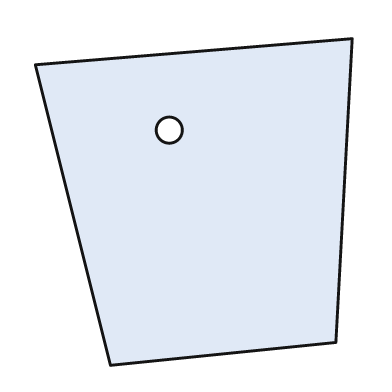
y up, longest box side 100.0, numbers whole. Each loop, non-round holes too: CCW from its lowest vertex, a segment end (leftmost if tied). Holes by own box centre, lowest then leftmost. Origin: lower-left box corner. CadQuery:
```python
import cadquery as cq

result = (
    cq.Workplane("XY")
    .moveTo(23.0, 0.0)
    .lineTo(92.0, 7.0)
    .lineTo(97.0, 100.0)
    .lineTo(0.0, 92.0)
    .close()
    .moveTo(41.0, 72.0)
    .circle(4.0)
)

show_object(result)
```